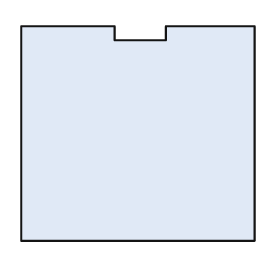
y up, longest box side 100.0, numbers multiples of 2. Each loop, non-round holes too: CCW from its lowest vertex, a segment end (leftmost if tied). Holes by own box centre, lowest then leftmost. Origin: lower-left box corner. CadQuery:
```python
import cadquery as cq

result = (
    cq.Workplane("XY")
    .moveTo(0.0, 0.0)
    .lineTo(100.0, 0.0)
    .lineTo(100.0, 92.0)
    .lineTo(62.0, 92.0)
    .lineTo(62.0, 86.0)
    .lineTo(40.0, 86.0)
    .lineTo(40.0, 92.0)
    .lineTo(0.0, 92.0)
    .close()
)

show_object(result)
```